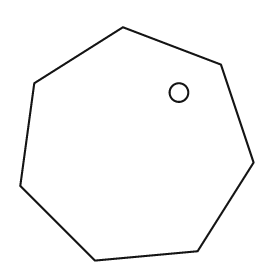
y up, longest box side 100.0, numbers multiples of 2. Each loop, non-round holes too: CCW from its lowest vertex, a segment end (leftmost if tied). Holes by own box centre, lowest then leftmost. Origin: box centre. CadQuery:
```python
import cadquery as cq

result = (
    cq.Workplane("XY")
    .moveTo(-18.0, -50.0)
    .lineTo(26.0, -46.0)
    .lineTo(50.0, -8.0)
    .lineTo(36.0, 34.0)
    .lineTo(-6.0, 50.0)
    .lineTo(-44.0, 26.0)
    .lineTo(-50.0, -18.0)
    .close()
    .moveTo(18.0, 22.0)
    .circle(4.0)
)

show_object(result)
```